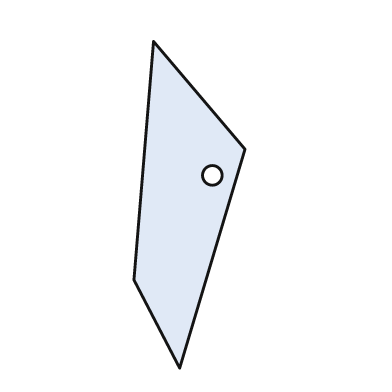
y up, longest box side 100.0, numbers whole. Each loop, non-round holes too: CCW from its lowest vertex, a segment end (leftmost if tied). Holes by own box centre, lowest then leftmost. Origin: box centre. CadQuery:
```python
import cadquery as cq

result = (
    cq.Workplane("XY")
    .moveTo(-3.0, -50.0)
    .lineTo(17.0, 17.0)
    .lineTo(-11.0, 50.0)
    .lineTo(-17.0, -23.0)
    .close()
    .moveTo(7.0, 9.0)
    .circle(3.0)
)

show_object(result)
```